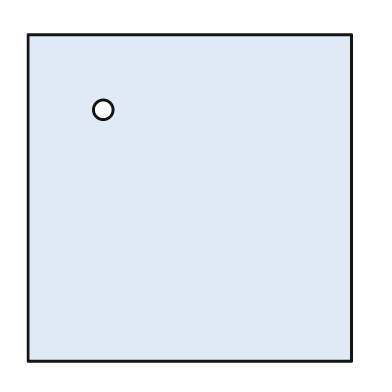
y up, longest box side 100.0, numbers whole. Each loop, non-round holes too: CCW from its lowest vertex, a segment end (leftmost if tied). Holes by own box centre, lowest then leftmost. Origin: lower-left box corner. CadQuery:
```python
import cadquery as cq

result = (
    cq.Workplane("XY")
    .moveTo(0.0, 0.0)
    .lineTo(99.0, 0.0)
    .lineTo(99.0, 100.0)
    .lineTo(0.0, 100.0)
    .close()
    .moveTo(23.0, 77.0)
    .circle(3.0)
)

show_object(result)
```